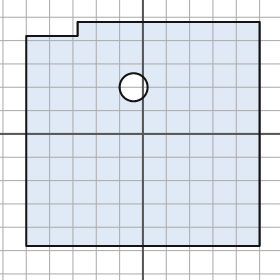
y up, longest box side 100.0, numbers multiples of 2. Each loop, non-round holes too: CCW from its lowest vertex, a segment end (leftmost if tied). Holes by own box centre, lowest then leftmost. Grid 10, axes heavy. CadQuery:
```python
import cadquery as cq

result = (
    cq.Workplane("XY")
    .moveTo(-50.0, -48.0)
    .lineTo(50.0, -48.0)
    .lineTo(50.0, 48.0)
    .lineTo(-28.0, 48.0)
    .lineTo(-28.0, 42.0)
    .lineTo(-50.0, 42.0)
    .close()
    .moveTo(-4.0, 20.0)
    .circle(6.0)
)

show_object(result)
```